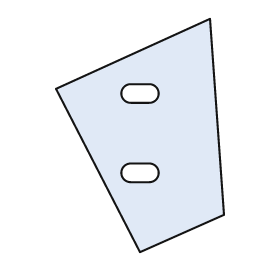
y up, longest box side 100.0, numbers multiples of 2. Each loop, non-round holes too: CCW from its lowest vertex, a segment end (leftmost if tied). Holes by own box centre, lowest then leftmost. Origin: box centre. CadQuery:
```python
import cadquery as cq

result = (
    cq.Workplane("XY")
    .moveTo(0.0, -50.0)
    .lineTo(36.0, -34.0)
    .lineTo(30.0, 50.0)
    .lineTo(-36.0, 20.0)
    .close()
    .moveTo(-4.0, -20.0)
    .lineTo(4.0, -20.0)
    .threePointArc((8.0, -16.0), (4.0, -12.0))
    .lineTo(-4.0, -12.0)
    .threePointArc((-8.0, -16.0), (-4.0, -20.0))
    .close()
    .moveTo(-4.0, 14.0)
    .lineTo(4.0, 14.0)
    .threePointArc((8.0, 18.0), (4.0, 22.0))
    .lineTo(-4.0, 22.0)
    .threePointArc((-8.0, 18.0), (-4.0, 14.0))
    .close()
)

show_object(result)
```